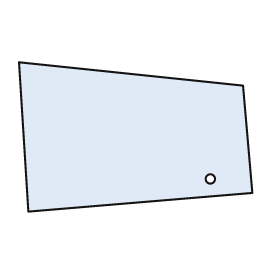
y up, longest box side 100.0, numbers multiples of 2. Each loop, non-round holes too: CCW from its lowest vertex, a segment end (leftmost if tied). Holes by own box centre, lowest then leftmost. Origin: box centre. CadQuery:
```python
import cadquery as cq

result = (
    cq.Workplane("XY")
    .moveTo(-46.0, -32.0)
    .lineTo(50.0, -24.0)
    .lineTo(46.0, 22.0)
    .lineTo(-50.0, 32.0)
    .close()
    .moveTo(32.0, -18.0)
    .circle(2.0)
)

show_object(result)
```